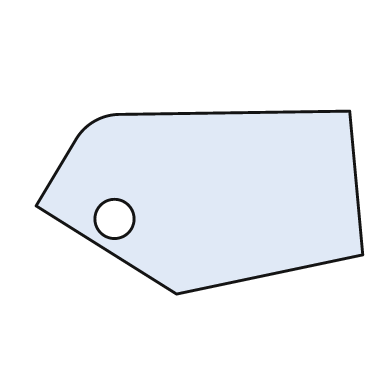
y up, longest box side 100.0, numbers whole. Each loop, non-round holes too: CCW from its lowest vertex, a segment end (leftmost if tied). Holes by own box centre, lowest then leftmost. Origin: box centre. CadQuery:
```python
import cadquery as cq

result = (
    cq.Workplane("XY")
    .moveTo(-7.0, -28.0)
    .lineTo(50.0, -16.0)
    .lineTo(46.0, 28.0)
    .lineTo(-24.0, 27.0)
    .threePointArc((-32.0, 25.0), (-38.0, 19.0))
    .lineTo(-50.0, -1.0)
    .close()
    .moveTo(-26.0, -5.0)
    .circle(6.0)
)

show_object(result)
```